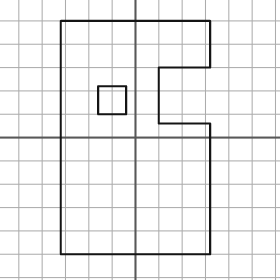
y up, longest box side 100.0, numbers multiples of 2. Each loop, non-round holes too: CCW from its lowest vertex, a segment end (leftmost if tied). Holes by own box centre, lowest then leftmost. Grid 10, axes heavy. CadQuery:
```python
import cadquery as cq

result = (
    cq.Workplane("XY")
    .moveTo(-32.0, -50.0)
    .lineTo(32.0, -50.0)
    .lineTo(32.0, 6.0)
    .lineTo(10.0, 6.0)
    .lineTo(10.0, 30.0)
    .lineTo(32.0, 30.0)
    .lineTo(32.0, 50.0)
    .lineTo(-32.0, 50.0)
    .close()
    .moveTo(-16.0, 10.0)
    .lineTo(-4.0, 10.0)
    .lineTo(-4.0, 22.0)
    .lineTo(-16.0, 22.0)
    .close()
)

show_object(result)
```